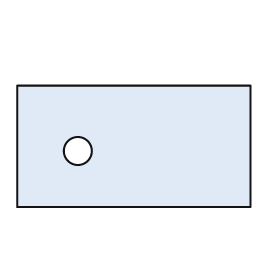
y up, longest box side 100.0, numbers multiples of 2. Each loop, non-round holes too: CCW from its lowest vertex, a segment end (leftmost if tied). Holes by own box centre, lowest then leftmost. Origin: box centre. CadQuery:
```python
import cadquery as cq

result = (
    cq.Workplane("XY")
    .moveTo(-50.0, -26.0)
    .lineTo(50.0, -26.0)
    .lineTo(50.0, 26.0)
    .lineTo(-50.0, 26.0)
    .close()
    .moveTo(-24.0, -2.0)
    .circle(6.0)
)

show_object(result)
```